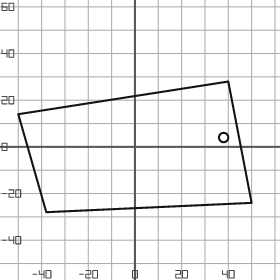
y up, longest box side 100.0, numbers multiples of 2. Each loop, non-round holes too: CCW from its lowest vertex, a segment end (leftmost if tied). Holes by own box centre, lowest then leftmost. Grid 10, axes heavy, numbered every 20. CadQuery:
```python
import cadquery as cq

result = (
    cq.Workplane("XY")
    .moveTo(-38.0, -28.0)
    .lineTo(50.0, -24.0)
    .lineTo(40.0, 28.0)
    .lineTo(-50.0, 14.0)
    .close()
    .moveTo(38.0, 4.0)
    .circle(2.0)
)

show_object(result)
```